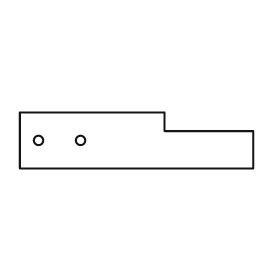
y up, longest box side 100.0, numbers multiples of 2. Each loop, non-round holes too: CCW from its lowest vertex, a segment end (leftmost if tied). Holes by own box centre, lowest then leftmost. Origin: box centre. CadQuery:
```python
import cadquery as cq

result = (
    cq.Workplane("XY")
    .moveTo(-50.0, -12.0)
    .lineTo(50.0, -12.0)
    .lineTo(50.0, 4.0)
    .lineTo(12.0, 4.0)
    .lineTo(12.0, 12.0)
    .lineTo(-50.0, 12.0)
    .close()
    .moveTo(-42.0, 0.0)
    .circle(2.0)
    .moveTo(-24.0, 0.0)
    .circle(2.0)
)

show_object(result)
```